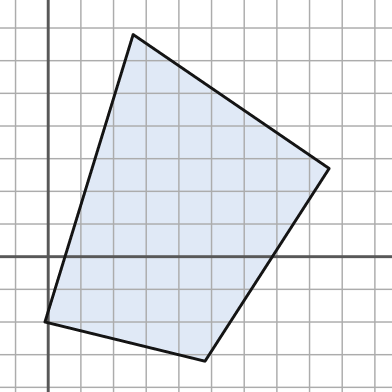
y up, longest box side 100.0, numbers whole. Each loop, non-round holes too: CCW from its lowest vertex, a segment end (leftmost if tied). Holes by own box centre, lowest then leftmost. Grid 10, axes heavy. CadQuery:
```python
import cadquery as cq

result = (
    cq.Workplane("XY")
    .moveTo(48.0, -32.0)
    .lineTo(86.0, 27.0)
    .lineTo(26.0, 68.0)
    .lineTo(-1.0, -20.0)
    .close()
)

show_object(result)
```